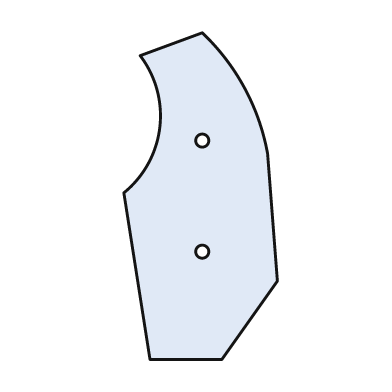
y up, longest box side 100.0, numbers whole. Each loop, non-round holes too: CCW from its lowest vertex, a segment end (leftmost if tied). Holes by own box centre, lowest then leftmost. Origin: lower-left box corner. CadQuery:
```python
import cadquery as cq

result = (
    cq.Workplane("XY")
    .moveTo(8.0, 0.0)
    .lineTo(30.0, 0.0)
    .lineTo(47.0, 24.0)
    .lineTo(44.0, 63.0)
    .threePointArc((37.0, 83.0), (24.0, 100.0))
    .lineTo(5.0, 93.0)
    .threePointArc((11.0, 71.0), (0.0, 51.0))
    .close()
    .moveTo(24.0, 33.0)
    .circle(2.0)
    .moveTo(24.0, 67.0)
    .circle(2.0)
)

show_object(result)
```